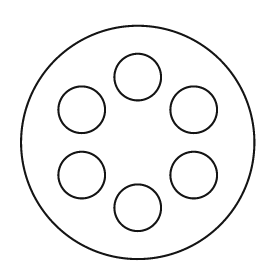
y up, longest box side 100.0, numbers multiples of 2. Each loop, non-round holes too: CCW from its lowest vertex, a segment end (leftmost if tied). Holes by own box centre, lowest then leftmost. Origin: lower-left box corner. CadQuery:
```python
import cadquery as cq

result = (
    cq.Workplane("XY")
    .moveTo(50.0, 50.0)
    .circle(50.0)
    .moveTo(50.0, 22.0)
    .circle(10.0)
    .moveTo(26.0, 36.0)
    .circle(10.0)
    .moveTo(74.0, 36.0)
    .circle(10.0)
    .moveTo(26.0, 64.0)
    .circle(10.0)
    .moveTo(74.0, 64.0)
    .circle(10.0)
    .moveTo(50.0, 78.0)
    .circle(10.0)
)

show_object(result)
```